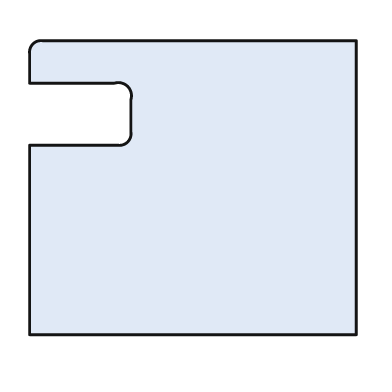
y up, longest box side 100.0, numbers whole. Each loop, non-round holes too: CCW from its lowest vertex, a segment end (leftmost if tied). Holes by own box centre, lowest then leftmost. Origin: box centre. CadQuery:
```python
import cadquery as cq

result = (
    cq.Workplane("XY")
    .moveTo(-50.0, -45.0)
    .lineTo(50.0, -45.0)
    .lineTo(50.0, 45.0)
    .lineTo(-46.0, 45.0)
    .threePointArc((-49.0, 44.0), (-50.0, 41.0))
    .lineTo(-50.0, 32.0)
    .lineTo(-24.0, 32.0)
    .threePointArc((-20.0, 31.0), (-19.0, 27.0))
    .lineTo(-19.0, 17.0)
    .threePointArc((-20.0, 14.0), (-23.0, 13.0))
    .lineTo(-50.0, 13.0)
    .close()
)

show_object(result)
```